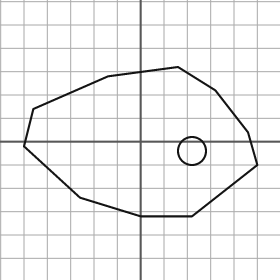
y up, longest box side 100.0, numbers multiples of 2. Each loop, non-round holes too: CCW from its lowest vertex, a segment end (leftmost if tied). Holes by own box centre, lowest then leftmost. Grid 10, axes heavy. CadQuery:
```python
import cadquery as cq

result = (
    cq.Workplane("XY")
    .moveTo(0.0, -32.0)
    .lineTo(22.0, -32.0)
    .lineTo(50.0, -10.0)
    .lineTo(46.0, 4.0)
    .lineTo(32.0, 22.0)
    .lineTo(16.0, 32.0)
    .lineTo(-14.0, 28.0)
    .lineTo(-46.0, 14.0)
    .lineTo(-50.0, -2.0)
    .lineTo(-26.0, -24.0)
    .close()
    .moveTo(22.0, -4.0)
    .circle(6.0)
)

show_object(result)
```